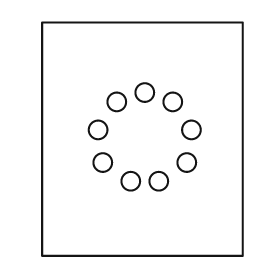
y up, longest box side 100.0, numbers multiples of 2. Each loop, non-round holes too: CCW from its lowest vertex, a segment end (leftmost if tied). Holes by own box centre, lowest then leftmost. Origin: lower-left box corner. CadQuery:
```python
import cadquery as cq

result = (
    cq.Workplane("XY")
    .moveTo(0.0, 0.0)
    .lineTo(86.0, 0.0)
    .lineTo(86.0, 100.0)
    .lineTo(0.0, 100.0)
    .close()
    .moveTo(38.0, 32.0)
    .circle(4.0)
    .moveTo(50.0, 32.0)
    .circle(4.0)
    .moveTo(26.0, 40.0)
    .circle(4.0)
    .moveTo(62.0, 40.0)
    .circle(4.0)
    .moveTo(24.0, 54.0)
    .circle(4.0)
    .moveTo(64.0, 54.0)
    .circle(4.0)
    .moveTo(32.0, 66.0)
    .circle(4.0)
    .moveTo(56.0, 66.0)
    .circle(4.0)
    .moveTo(44.0, 70.0)
    .circle(4.0)
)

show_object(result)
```